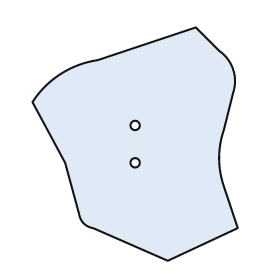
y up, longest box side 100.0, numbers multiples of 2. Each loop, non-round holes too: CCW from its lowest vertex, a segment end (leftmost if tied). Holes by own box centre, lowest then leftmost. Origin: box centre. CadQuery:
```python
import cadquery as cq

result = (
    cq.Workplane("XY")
    .moveTo(14.0, -50.0)
    .lineTo(44.0, -36.0)
    .lineTo(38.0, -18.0)
    .threePointArc((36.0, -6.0), (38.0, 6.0))
    .lineTo(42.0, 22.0)
    .threePointArc((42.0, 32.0), (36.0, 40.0))
    .lineTo(26.0, 50.0)
    .lineTo(-16.0, 36.0)
    .threePointArc((-32.0, 30.0), (-44.0, 18.0))
    .lineTo(-30.0, -8.0)
    .lineTo(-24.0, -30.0)
    .threePointArc((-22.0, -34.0), (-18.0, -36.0))
    .close()
    .moveTo(0.0, -8.0)
    .circle(2.0)
    .moveTo(0.0, 8.0)
    .circle(2.0)
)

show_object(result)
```